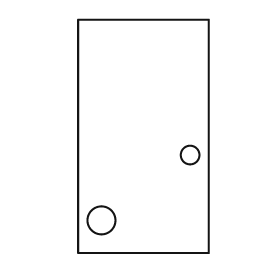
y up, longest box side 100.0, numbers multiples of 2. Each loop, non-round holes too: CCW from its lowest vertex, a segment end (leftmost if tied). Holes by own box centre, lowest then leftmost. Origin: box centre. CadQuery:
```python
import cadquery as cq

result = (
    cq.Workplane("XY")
    .moveTo(-28.0, -50.0)
    .lineTo(28.0, -50.0)
    .lineTo(28.0, 50.0)
    .lineTo(-28.0, 50.0)
    .close()
    .moveTo(-18.0, -36.0)
    .circle(6.0)
    .moveTo(20.0, -8.0)
    .circle(4.0)
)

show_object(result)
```